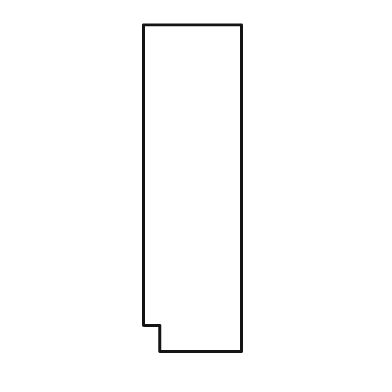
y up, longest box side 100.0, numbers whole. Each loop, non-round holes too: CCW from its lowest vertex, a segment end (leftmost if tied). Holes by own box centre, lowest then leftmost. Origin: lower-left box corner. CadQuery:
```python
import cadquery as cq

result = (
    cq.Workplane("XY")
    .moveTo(5.0, 0.0)
    .lineTo(30.0, 0.0)
    .lineTo(30.0, 100.0)
    .lineTo(0.0, 100.0)
    .lineTo(0.0, 8.0)
    .lineTo(5.0, 8.0)
    .close()
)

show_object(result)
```